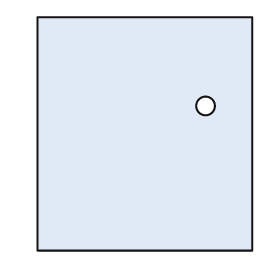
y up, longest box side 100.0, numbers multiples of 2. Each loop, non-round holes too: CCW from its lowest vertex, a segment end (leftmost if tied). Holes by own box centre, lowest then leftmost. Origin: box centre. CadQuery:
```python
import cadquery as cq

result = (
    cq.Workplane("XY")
    .moveTo(-46.0, -50.0)
    .lineTo(46.0, -50.0)
    .lineTo(46.0, 50.0)
    .lineTo(-46.0, 50.0)
    .close()
    .moveTo(26.0, 12.0)
    .circle(4.0)
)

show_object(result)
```